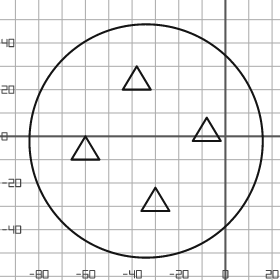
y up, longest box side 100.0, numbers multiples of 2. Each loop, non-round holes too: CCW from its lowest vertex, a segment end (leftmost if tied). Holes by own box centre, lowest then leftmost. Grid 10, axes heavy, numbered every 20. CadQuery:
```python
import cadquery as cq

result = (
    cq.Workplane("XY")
    .moveTo(-34.0, -2.0)
    .circle(50.0)
    .moveTo(-36.0, -32.0)
    .lineTo(-24.0, -32.0)
    .lineTo(-30.0, -22.0)
    .close()
    .moveTo(-66.0, -10.0)
    .lineTo(-54.0, -10.0)
    .lineTo(-60.0, 0.0)
    .close()
    .moveTo(-14.0, -2.0)
    .lineTo(-2.0, -2.0)
    .lineTo(-8.0, 8.0)
    .close()
    .moveTo(-44.0, 20.0)
    .lineTo(-32.0, 20.0)
    .lineTo(-38.0, 30.0)
    .close()
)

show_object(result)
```